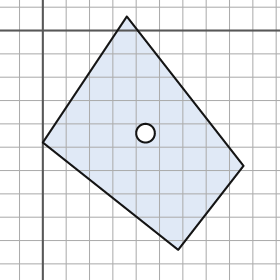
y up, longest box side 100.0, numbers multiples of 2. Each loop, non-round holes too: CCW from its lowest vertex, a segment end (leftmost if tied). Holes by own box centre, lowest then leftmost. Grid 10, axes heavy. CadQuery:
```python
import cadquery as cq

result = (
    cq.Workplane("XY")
    .moveTo(58.0, -94.0)
    .lineTo(86.0, -58.0)
    .lineTo(36.0, 6.0)
    .lineTo(0.0, -48.0)
    .close()
    .moveTo(44.0, -44.0)
    .circle(4.0)
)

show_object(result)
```